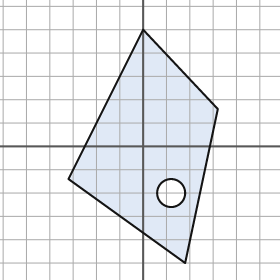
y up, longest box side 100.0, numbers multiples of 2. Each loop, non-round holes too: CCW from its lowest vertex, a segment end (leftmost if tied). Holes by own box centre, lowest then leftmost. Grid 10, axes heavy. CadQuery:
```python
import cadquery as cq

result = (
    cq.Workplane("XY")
    .moveTo(18.0, -50.0)
    .lineTo(32.0, 16.0)
    .lineTo(0.0, 50.0)
    .lineTo(-32.0, -14.0)
    .close()
    .moveTo(12.0, -20.0)
    .circle(6.0)
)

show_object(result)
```